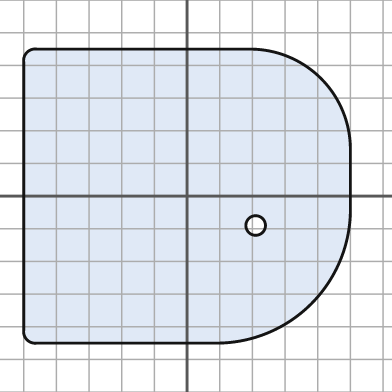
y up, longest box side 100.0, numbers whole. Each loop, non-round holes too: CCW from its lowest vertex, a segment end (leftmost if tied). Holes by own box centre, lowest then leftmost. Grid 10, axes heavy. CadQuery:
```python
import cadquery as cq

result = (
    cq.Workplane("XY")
    .moveTo(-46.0, -45.0)
    .lineTo(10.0, -45.0)
    .threePointArc((38.0, -33.0), (50.0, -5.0))
    .lineTo(50.0, 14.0)
    .threePointArc((41.0, 36.0), (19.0, 45.0))
    .lineTo(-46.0, 45.0)
    .threePointArc((-49.0, 44.0), (-50.0, 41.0))
    .lineTo(-50.0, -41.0)
    .threePointArc((-49.0, -44.0), (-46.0, -45.0))
    .close()
    .moveTo(21.0, -9.0)
    .circle(3.0)
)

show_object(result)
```